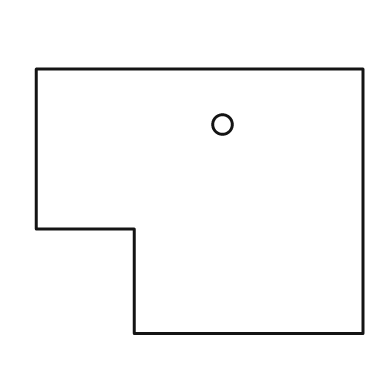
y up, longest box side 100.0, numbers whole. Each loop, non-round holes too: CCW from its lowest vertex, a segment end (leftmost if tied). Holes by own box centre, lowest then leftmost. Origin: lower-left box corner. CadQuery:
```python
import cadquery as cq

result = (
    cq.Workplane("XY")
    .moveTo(30.0, 0.0)
    .lineTo(100.0, 0.0)
    .lineTo(100.0, 81.0)
    .lineTo(0.0, 81.0)
    .lineTo(0.0, 32.0)
    .lineTo(30.0, 32.0)
    .close()
    .moveTo(57.0, 64.0)
    .circle(3.0)
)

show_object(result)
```